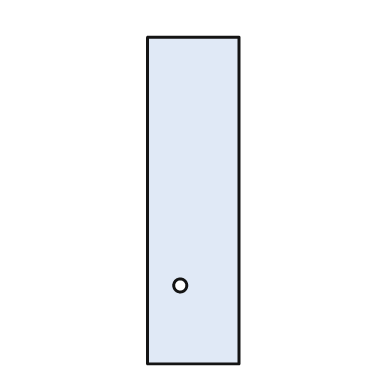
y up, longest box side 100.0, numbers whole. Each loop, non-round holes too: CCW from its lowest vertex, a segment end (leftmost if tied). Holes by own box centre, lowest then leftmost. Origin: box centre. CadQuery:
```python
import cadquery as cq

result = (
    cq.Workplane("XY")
    .moveTo(-14.0, -50.0)
    .lineTo(14.0, -50.0)
    .lineTo(14.0, 50.0)
    .lineTo(-14.0, 50.0)
    .close()
    .moveTo(-4.0, -26.0)
    .circle(2.0)
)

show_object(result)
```